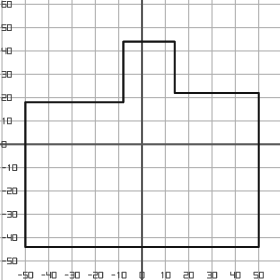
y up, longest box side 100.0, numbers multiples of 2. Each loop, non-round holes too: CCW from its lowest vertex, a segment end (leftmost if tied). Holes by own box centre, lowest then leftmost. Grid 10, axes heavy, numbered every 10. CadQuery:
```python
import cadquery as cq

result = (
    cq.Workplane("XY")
    .moveTo(-50.0, -44.0)
    .lineTo(50.0, -44.0)
    .lineTo(50.0, 22.0)
    .lineTo(14.0, 22.0)
    .lineTo(14.0, 44.0)
    .lineTo(-8.0, 44.0)
    .lineTo(-8.0, 18.0)
    .lineTo(-50.0, 18.0)
    .close()
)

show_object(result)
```